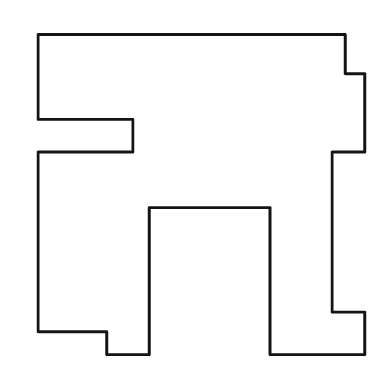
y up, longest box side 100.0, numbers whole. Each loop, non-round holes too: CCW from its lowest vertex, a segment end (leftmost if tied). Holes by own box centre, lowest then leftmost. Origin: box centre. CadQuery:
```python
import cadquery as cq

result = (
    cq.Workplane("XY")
    .moveTo(-29.0, -49.0)
    .lineTo(-16.0, -49.0)
    .lineTo(-16.0, -4.0)
    .lineTo(21.0, -4.0)
    .lineTo(21.0, -49.0)
    .lineTo(50.0, -49.0)
    .lineTo(50.0, -36.0)
    .lineTo(40.0, -36.0)
    .lineTo(40.0, 13.0)
    .lineTo(50.0, 13.0)
    .lineTo(50.0, 37.0)
    .lineTo(44.0, 37.0)
    .lineTo(44.0, 49.0)
    .lineTo(-50.0, 49.0)
    .lineTo(-50.0, 23.0)
    .lineTo(-21.0, 23.0)
    .lineTo(-21.0, 13.0)
    .lineTo(-50.0, 13.0)
    .lineTo(-50.0, -42.0)
    .lineTo(-29.0, -42.0)
    .close()
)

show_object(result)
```